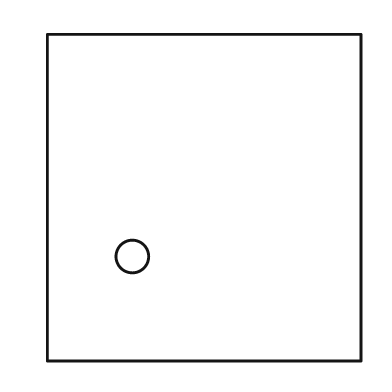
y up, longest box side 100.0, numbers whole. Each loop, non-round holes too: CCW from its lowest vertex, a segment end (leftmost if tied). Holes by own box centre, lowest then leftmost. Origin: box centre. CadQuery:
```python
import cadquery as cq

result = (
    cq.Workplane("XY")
    .moveTo(-48.0, -50.0)
    .lineTo(48.0, -50.0)
    .lineTo(48.0, 50.0)
    .lineTo(-48.0, 50.0)
    .close()
    .moveTo(-22.0, -18.0)
    .circle(5.0)
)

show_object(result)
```